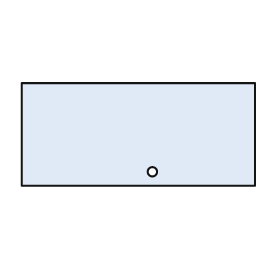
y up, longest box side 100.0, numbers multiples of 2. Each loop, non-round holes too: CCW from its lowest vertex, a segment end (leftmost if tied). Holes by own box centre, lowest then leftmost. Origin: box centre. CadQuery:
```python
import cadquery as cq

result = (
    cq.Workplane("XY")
    .moveTo(-50.0, -22.0)
    .lineTo(50.0, -22.0)
    .lineTo(50.0, 22.0)
    .lineTo(-50.0, 22.0)
    .close()
    .moveTo(6.0, -16.0)
    .circle(2.0)
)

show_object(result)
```